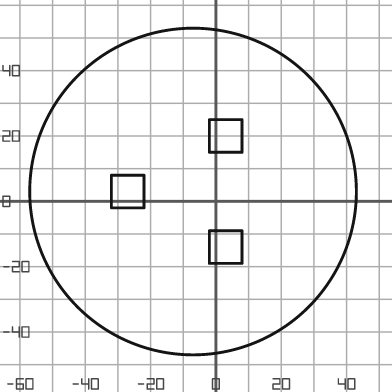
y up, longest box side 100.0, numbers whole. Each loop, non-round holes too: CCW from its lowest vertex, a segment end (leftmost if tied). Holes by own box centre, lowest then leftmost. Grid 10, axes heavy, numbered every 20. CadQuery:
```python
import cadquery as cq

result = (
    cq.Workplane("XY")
    .moveTo(-7.0, 3.0)
    .circle(50.0)
    .moveTo(-2.0, -19.0)
    .lineTo(8.0, -19.0)
    .lineTo(8.0, -9.0)
    .lineTo(-2.0, -9.0)
    .close()
    .moveTo(-32.0, -2.0)
    .lineTo(-22.0, -2.0)
    .lineTo(-22.0, 8.0)
    .lineTo(-32.0, 8.0)
    .close()
    .moveTo(-2.0, 15.0)
    .lineTo(8.0, 15.0)
    .lineTo(8.0, 25.0)
    .lineTo(-2.0, 25.0)
    .close()
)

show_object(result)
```